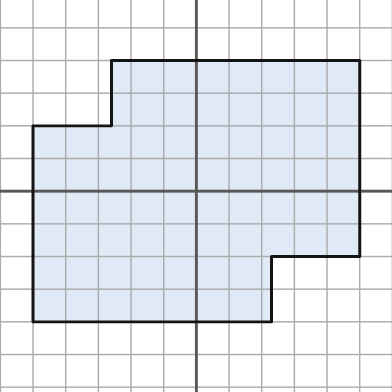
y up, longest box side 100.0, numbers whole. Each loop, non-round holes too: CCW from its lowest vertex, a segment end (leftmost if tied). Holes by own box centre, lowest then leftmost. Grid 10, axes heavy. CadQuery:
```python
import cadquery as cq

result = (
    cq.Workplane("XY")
    .moveTo(-50.0, -40.0)
    .lineTo(23.0, -40.0)
    .lineTo(23.0, -20.0)
    .lineTo(50.0, -20.0)
    .lineTo(50.0, 40.0)
    .lineTo(-26.0, 40.0)
    .lineTo(-26.0, 20.0)
    .lineTo(-50.0, 20.0)
    .close()
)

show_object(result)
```